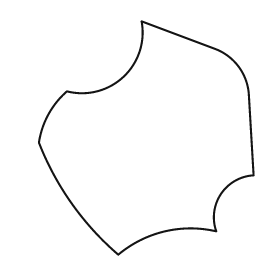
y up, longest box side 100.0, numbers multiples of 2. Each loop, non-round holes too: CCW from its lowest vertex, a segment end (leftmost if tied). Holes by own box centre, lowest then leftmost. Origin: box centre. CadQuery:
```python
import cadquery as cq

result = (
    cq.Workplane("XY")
    .moveTo(-12.0, -50.0)
    .threePointArc((8.0, -40.0), (30.0, -40.0))
    .threePointArc((32.0, -24.0), (46.0, -16.0))
    .lineTo(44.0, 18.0)
    .threePointArc((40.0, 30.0), (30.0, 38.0))
    .lineTo(-2.0, 50.0)
    .threePointArc((-10.0, 26.0), (-34.0, 20.0))
    .threePointArc((-42.0, 10.0), (-46.0, -2.0))
    .threePointArc((-32.0, -28.0), (-12.0, -50.0))
    .close()
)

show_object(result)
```